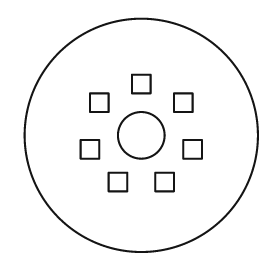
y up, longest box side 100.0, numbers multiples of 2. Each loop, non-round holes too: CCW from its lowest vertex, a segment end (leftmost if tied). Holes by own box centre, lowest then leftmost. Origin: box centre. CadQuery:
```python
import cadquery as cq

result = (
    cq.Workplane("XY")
    .moveTo(0.0, 0.0)
    .circle(50.0)
    .moveTo(-14.0, -24.0)
    .lineTo(-6.0, -24.0)
    .lineTo(-6.0, -16.0)
    .lineTo(-14.0, -16.0)
    .close()
    .moveTo(6.0, -24.0)
    .lineTo(14.0, -24.0)
    .lineTo(14.0, -16.0)
    .lineTo(6.0, -16.0)
    .close()
    .moveTo(-26.0, -10.0)
    .lineTo(-18.0, -10.0)
    .lineTo(-18.0, -2.0)
    .lineTo(-26.0, -2.0)
    .close()
    .moveTo(18.0, -10.0)
    .lineTo(26.0, -10.0)
    .lineTo(26.0, -2.0)
    .lineTo(18.0, -2.0)
    .close()
    .moveTo(0.0, 0.0)
    .circle(10.0)
    .moveTo(-22.0, 10.0)
    .lineTo(-14.0, 10.0)
    .lineTo(-14.0, 18.0)
    .lineTo(-22.0, 18.0)
    .close()
    .moveTo(14.0, 10.0)
    .lineTo(22.0, 10.0)
    .lineTo(22.0, 18.0)
    .lineTo(14.0, 18.0)
    .close()
    .moveTo(-4.0, 18.0)
    .lineTo(4.0, 18.0)
    .lineTo(4.0, 26.0)
    .lineTo(-4.0, 26.0)
    .close()
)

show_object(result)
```